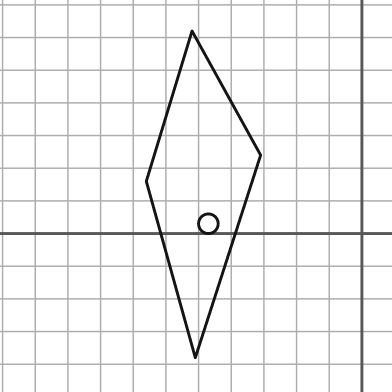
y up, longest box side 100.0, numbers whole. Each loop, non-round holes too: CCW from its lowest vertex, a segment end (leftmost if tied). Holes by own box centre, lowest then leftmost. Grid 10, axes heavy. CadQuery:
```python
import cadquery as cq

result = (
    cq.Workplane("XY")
    .moveTo(-51.0, -38.0)
    .lineTo(-31.0, 24.0)
    .lineTo(-52.0, 62.0)
    .lineTo(-66.0, 16.0)
    .close()
    .moveTo(-47.0, 3.0)
    .circle(3.0)
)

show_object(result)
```